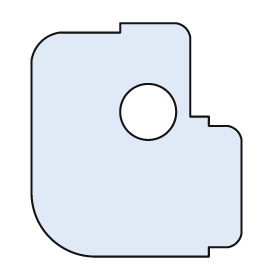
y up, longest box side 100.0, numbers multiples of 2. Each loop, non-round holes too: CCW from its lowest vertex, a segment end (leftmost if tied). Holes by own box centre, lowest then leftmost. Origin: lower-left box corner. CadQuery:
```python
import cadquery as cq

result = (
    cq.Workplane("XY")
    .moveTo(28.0, 0.0)
    .lineTo(76.0, 0.0)
    .lineTo(76.0, 4.0)
    .lineTo(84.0, 4.0)
    .threePointArc((88.0, 6.0), (90.0, 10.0))
    .lineTo(90.0, 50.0)
    .threePointArc((88.0, 54.0), (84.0, 56.0))
    .lineTo(76.0, 56.0)
    .lineTo(76.0, 60.0)
    .lineTo(68.0, 60.0)
    .lineTo(68.0, 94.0)
    .threePointArc((66.0, 98.0), (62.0, 100.0))
    .lineTo(38.0, 100.0)
    .lineTo(38.0, 96.0)
    .lineTo(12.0, 96.0)
    .threePointArc((4.0, 92.0), (0.0, 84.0))
    .lineTo(0.0, 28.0)
    .threePointArc((8.0, 8.0), (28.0, 0.0))
    .close()
    .moveTo(50.0, 62.0)
    .circle(12.0)
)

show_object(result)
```